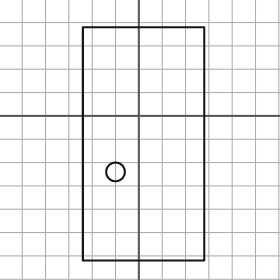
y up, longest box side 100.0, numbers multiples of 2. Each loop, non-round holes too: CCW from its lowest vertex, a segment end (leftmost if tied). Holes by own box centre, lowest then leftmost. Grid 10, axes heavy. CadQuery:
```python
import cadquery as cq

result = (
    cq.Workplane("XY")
    .moveTo(-24.0, -62.0)
    .lineTo(28.0, -62.0)
    .lineTo(28.0, 38.0)
    .lineTo(-24.0, 38.0)
    .close()
    .moveTo(-10.0, -24.0)
    .circle(4.0)
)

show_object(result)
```